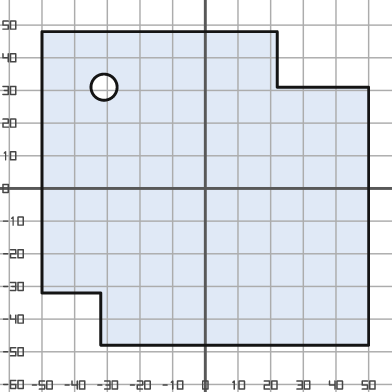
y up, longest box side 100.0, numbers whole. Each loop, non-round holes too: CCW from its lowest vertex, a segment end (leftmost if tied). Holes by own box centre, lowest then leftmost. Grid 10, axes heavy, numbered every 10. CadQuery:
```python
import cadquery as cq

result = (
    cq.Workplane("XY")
    .moveTo(-32.0, -48.0)
    .lineTo(50.0, -48.0)
    .lineTo(50.0, 31.0)
    .lineTo(22.0, 31.0)
    .lineTo(22.0, 48.0)
    .lineTo(-50.0, 48.0)
    .lineTo(-50.0, -32.0)
    .lineTo(-32.0, -32.0)
    .close()
    .moveTo(-31.0, 31.0)
    .circle(4.0)
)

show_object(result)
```